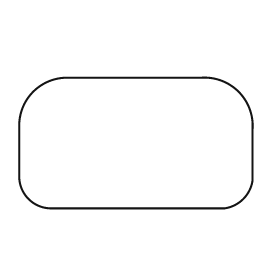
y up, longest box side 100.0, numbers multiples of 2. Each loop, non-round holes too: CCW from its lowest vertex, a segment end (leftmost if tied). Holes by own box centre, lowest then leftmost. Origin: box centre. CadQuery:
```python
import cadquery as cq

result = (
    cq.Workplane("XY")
    .moveTo(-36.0, -28.0)
    .lineTo(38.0, -28.0)
    .threePointArc((46.0, -24.0), (50.0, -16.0))
    .lineTo(50.0, 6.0)
    .threePointArc((44.0, 22.0), (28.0, 28.0))
    .lineTo(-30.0, 28.0)
    .threePointArc((-44.0, 22.0), (-50.0, 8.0))
    .lineTo(-50.0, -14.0)
    .threePointArc((-46.0, -24.0), (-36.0, -28.0))
    .close()
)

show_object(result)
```